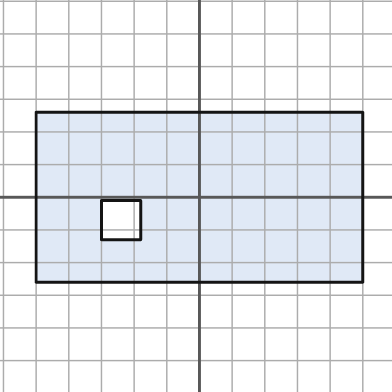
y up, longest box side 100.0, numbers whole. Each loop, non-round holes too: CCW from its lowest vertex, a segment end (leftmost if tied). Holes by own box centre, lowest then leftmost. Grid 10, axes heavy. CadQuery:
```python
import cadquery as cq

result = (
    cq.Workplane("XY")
    .moveTo(-50.0, -26.0)
    .lineTo(50.0, -26.0)
    .lineTo(50.0, 26.0)
    .lineTo(-50.0, 26.0)
    .close()
    .moveTo(-30.0, -13.0)
    .lineTo(-18.0, -13.0)
    .lineTo(-18.0, -1.0)
    .lineTo(-30.0, -1.0)
    .close()
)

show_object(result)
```